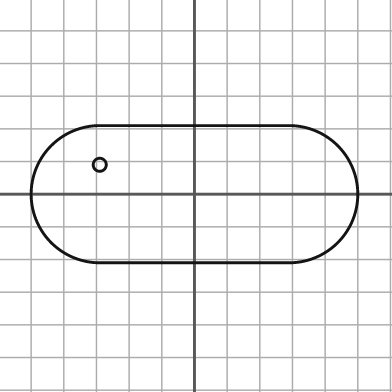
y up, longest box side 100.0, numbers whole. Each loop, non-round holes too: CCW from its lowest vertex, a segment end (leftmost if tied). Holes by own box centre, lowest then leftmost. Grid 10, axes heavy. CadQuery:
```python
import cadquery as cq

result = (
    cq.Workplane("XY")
    .moveTo(-29.0, -21.0)
    .lineTo(29.0, -21.0)
    .threePointArc((50.0, 0.0), (29.0, 21.0))
    .lineTo(-29.0, 21.0)
    .threePointArc((-50.0, 0.0), (-29.0, -21.0))
    .close()
    .moveTo(-29.0, 9.0)
    .circle(2.0)
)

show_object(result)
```